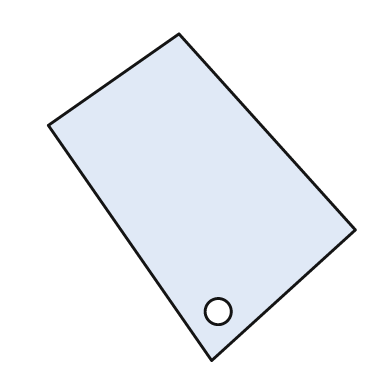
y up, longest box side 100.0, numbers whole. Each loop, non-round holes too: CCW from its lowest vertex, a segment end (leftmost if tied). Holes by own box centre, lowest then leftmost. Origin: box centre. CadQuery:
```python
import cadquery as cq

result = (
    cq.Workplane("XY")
    .moveTo(3.0, -50.0)
    .lineTo(47.0, -10.0)
    .lineTo(-7.0, 50.0)
    .lineTo(-47.0, 22.0)
    .close()
    .moveTo(5.0, -35.0)
    .circle(4.0)
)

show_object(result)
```